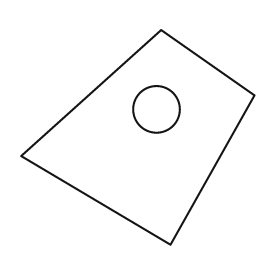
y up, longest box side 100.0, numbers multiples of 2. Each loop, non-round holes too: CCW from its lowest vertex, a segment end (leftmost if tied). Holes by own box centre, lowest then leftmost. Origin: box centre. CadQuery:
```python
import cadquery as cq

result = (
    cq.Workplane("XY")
    .moveTo(14.0, -46.0)
    .lineTo(50.0, 18.0)
    .lineTo(10.0, 46.0)
    .lineTo(-50.0, -8.0)
    .close()
    .moveTo(8.0, 12.0)
    .circle(10.0)
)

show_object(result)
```